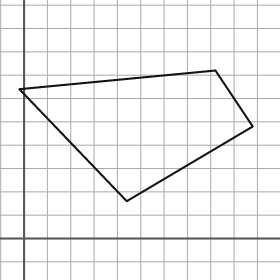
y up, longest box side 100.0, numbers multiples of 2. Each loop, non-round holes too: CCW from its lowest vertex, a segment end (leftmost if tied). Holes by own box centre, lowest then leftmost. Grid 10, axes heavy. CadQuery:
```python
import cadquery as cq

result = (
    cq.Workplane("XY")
    .moveTo(44.0, 16.0)
    .lineTo(98.0, 48.0)
    .lineTo(82.0, 72.0)
    .lineTo(-2.0, 64.0)
    .close()
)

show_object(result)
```